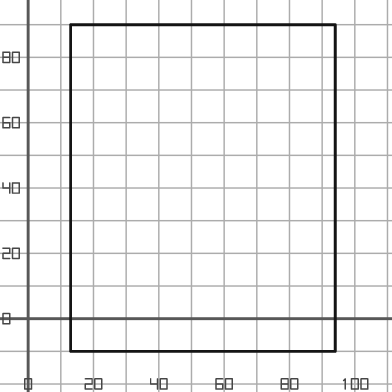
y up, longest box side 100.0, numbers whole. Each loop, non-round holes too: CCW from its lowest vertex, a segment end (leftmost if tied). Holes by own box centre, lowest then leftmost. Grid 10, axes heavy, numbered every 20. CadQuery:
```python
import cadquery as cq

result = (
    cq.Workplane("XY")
    .moveTo(13.0, -10.0)
    .lineTo(94.0, -10.0)
    .lineTo(94.0, 90.0)
    .lineTo(13.0, 90.0)
    .close()
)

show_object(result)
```